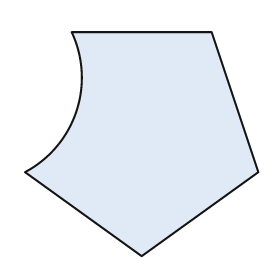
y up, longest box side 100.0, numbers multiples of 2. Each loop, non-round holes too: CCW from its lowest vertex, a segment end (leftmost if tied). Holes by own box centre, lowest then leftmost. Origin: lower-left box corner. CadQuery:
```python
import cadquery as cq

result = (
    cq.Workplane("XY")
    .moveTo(50.0, 0.0)
    .lineTo(100.0, 36.0)
    .lineTo(80.0, 96.0)
    .lineTo(20.0, 96.0)
    .threePointArc((22.0, 62.0), (0.0, 36.0))
    .close()
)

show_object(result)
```